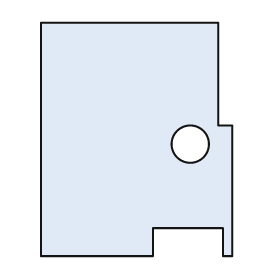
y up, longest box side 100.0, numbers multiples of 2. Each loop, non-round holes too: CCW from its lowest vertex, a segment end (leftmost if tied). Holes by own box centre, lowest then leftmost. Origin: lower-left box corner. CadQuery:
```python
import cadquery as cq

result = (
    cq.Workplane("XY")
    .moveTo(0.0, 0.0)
    .lineTo(48.0, 0.0)
    .lineTo(48.0, 12.0)
    .lineTo(78.0, 12.0)
    .lineTo(78.0, 0.0)
    .lineTo(82.0, 0.0)
    .lineTo(82.0, 56.0)
    .lineTo(76.0, 56.0)
    .lineTo(76.0, 100.0)
    .lineTo(0.0, 100.0)
    .close()
    .moveTo(64.0, 48.0)
    .circle(8.0)
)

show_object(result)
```